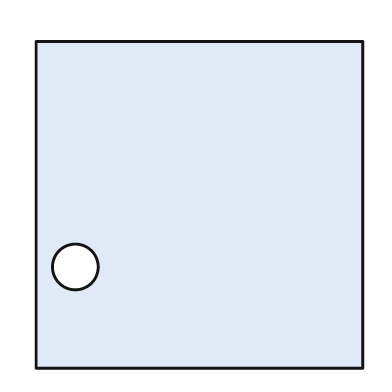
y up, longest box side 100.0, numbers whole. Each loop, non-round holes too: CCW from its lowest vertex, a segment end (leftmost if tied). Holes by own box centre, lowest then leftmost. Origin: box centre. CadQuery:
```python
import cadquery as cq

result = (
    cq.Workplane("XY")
    .moveTo(-50.0, -50.0)
    .lineTo(50.0, -50.0)
    .lineTo(50.0, 50.0)
    .lineTo(-50.0, 50.0)
    .close()
    .moveTo(-38.0, -19.0)
    .circle(7.0)
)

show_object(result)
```